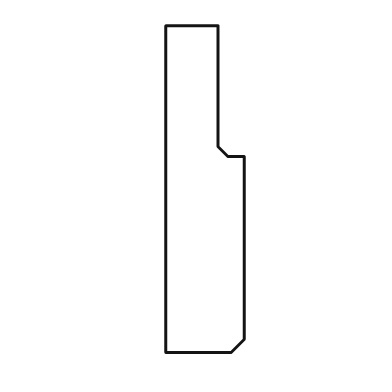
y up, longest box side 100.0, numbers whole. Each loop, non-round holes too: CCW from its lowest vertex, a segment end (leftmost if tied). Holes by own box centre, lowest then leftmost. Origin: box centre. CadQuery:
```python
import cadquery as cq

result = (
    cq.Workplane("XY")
    .moveTo(-12.0, -50.0)
    .lineTo(8.0, -50.0)
    .lineTo(12.0, -46.0)
    .lineTo(12.0, 10.0)
    .lineTo(7.0, 10.0)
    .lineTo(4.0, 13.0)
    .lineTo(4.0, 50.0)
    .lineTo(-12.0, 50.0)
    .close()
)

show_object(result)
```